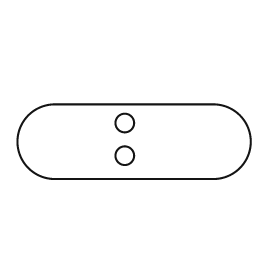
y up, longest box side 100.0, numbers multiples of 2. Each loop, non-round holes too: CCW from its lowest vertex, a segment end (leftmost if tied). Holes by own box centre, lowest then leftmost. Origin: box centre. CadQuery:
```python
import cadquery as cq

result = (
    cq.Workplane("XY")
    .moveTo(-34.0, -16.0)
    .lineTo(34.0, -16.0)
    .threePointArc((50.0, 0.0), (34.0, 16.0))
    .lineTo(-34.0, 16.0)
    .threePointArc((-50.0, 0.0), (-34.0, -16.0))
    .close()
    .moveTo(-4.0, -6.0)
    .circle(4.0)
    .moveTo(-4.0, 8.0)
    .circle(4.0)
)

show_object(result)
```